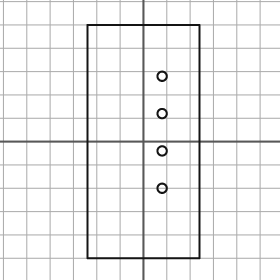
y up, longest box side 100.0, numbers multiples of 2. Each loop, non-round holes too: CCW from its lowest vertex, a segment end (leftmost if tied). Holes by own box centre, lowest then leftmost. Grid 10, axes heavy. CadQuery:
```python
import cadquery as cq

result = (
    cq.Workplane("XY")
    .moveTo(-24.0, -50.0)
    .lineTo(24.0, -50.0)
    .lineTo(24.0, 50.0)
    .lineTo(-24.0, 50.0)
    .close()
    .moveTo(8.0, -20.0)
    .circle(2.0)
    .moveTo(8.0, -4.0)
    .circle(2.0)
    .moveTo(8.0, 12.0)
    .circle(2.0)
    .moveTo(8.0, 28.0)
    .circle(2.0)
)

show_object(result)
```